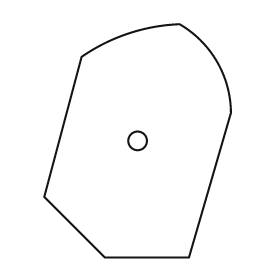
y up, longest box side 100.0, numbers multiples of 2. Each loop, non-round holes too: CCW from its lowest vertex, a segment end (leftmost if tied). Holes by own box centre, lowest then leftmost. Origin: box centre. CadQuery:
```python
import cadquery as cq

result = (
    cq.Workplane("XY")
    .moveTo(-14.0, -50.0)
    .lineTo(22.0, -50.0)
    .lineTo(40.0, 12.0)
    .threePointArc((34.0, 34.0), (18.0, 50.0))
    .threePointArc((-4.0, 46.0), (-24.0, 36.0))
    .lineTo(-40.0, -24.0)
    .close()
    .moveTo(0.0, 0.0)
    .circle(4.0)
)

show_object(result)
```